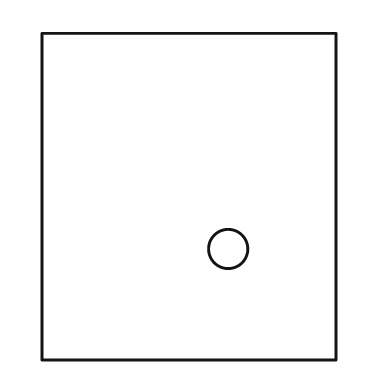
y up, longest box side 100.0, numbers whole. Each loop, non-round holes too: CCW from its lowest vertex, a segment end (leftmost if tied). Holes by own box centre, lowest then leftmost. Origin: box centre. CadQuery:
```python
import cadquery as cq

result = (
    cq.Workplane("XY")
    .moveTo(-45.0, -50.0)
    .lineTo(45.0, -50.0)
    .lineTo(45.0, 50.0)
    .lineTo(-45.0, 50.0)
    .close()
    .moveTo(12.0, -16.0)
    .circle(6.0)
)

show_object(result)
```